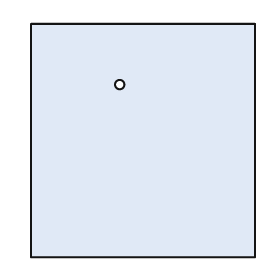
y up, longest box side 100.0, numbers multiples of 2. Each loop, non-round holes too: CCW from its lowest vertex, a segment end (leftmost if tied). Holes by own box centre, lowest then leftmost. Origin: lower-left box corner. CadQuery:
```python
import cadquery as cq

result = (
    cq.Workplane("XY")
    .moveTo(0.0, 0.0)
    .lineTo(96.0, 0.0)
    .lineTo(96.0, 100.0)
    .lineTo(0.0, 100.0)
    .close()
    .moveTo(38.0, 74.0)
    .circle(2.0)
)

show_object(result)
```